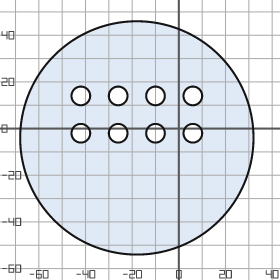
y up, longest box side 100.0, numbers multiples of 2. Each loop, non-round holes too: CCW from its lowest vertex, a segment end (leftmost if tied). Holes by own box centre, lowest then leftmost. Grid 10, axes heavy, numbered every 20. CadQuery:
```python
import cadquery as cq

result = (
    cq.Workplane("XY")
    .moveTo(-18.0, -4.0)
    .circle(50.0)
    .moveTo(-42.0, -2.0)
    .circle(4.0)
    .moveTo(-26.0, -2.0)
    .circle(4.0)
    .moveTo(-10.0, -2.0)
    .circle(4.0)
    .moveTo(6.0, -2.0)
    .circle(4.0)
    .moveTo(-42.0, 14.0)
    .circle(4.0)
    .moveTo(-26.0, 14.0)
    .circle(4.0)
    .moveTo(-10.0, 14.0)
    .circle(4.0)
    .moveTo(6.0, 14.0)
    .circle(4.0)
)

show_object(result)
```